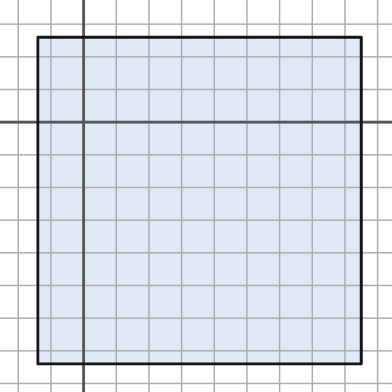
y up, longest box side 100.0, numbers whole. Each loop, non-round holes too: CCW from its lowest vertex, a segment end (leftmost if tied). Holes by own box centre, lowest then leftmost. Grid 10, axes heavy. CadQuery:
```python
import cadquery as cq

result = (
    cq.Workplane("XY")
    .moveTo(-14.0, -74.0)
    .lineTo(85.0, -74.0)
    .lineTo(85.0, 26.0)
    .lineTo(-14.0, 26.0)
    .close()
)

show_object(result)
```